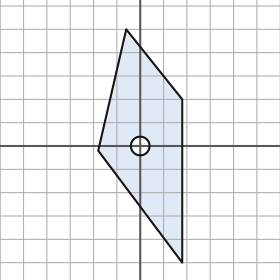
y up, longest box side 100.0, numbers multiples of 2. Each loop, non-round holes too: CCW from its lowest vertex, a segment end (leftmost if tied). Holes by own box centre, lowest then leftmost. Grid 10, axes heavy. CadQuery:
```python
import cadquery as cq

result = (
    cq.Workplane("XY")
    .moveTo(18.0, -50.0)
    .lineTo(18.0, 20.0)
    .lineTo(-6.0, 50.0)
    .lineTo(-18.0, -2.0)
    .close()
    .moveTo(0.0, 0.0)
    .circle(4.0)
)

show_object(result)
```